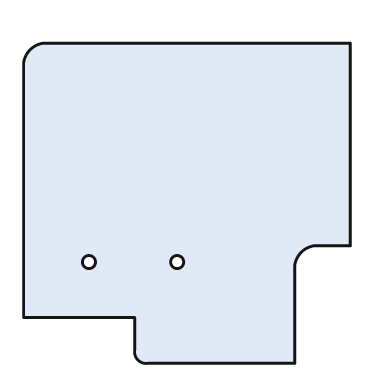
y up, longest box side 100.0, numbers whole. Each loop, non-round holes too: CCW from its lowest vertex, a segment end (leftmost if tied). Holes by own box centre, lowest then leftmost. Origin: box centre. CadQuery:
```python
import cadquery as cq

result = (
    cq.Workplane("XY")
    .moveTo(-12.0, -49.0)
    .lineTo(33.0, -49.0)
    .lineTo(33.0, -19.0)
    .threePointArc((35.0, -15.0), (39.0, -13.0))
    .lineTo(50.0, -13.0)
    .lineTo(50.0, 49.0)
    .lineTo(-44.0, 49.0)
    .threePointArc((-48.0, 47.0), (-50.0, 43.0))
    .lineTo(-50.0, -35.0)
    .lineTo(-16.0, -35.0)
    .lineTo(-16.0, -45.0)
    .threePointArc((-15.0, -48.0), (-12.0, -49.0))
    .close()
    .moveTo(-30.0, -18.0)
    .circle(2.0)
    .moveTo(-3.0, -18.0)
    .circle(2.0)
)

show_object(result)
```